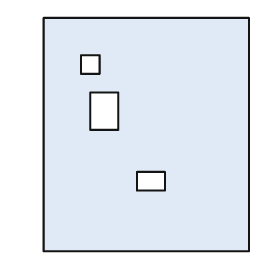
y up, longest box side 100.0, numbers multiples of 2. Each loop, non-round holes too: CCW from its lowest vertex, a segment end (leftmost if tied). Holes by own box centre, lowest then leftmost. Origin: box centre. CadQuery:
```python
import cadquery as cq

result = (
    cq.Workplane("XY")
    .moveTo(-44.0, -50.0)
    .lineTo(44.0, -50.0)
    .lineTo(44.0, 50.0)
    .lineTo(-44.0, 50.0)
    .close()
    .moveTo(-4.0, -24.0)
    .lineTo(8.0, -24.0)
    .lineTo(8.0, -16.0)
    .lineTo(-4.0, -16.0)
    .close()
    .moveTo(-24.0, 2.0)
    .lineTo(-12.0, 2.0)
    .lineTo(-12.0, 18.0)
    .lineTo(-24.0, 18.0)
    .close()
    .moveTo(-28.0, 26.0)
    .lineTo(-20.0, 26.0)
    .lineTo(-20.0, 34.0)
    .lineTo(-28.0, 34.0)
    .close()
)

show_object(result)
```